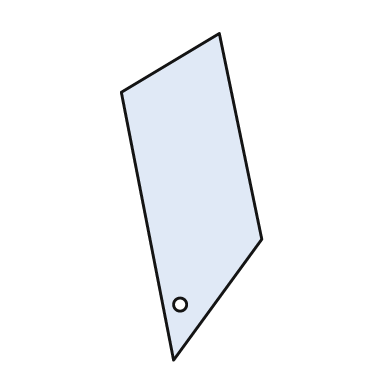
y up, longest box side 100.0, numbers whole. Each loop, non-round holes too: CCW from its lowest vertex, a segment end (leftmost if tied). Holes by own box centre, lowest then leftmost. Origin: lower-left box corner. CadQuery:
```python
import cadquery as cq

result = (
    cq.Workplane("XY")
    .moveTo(16.0, 0.0)
    .lineTo(43.0, 37.0)
    .lineTo(30.0, 100.0)
    .lineTo(0.0, 82.0)
    .close()
    .moveTo(18.0, 17.0)
    .circle(2.0)
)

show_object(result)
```